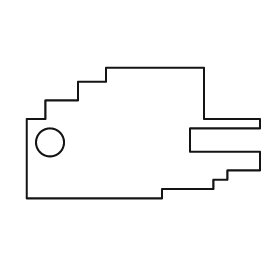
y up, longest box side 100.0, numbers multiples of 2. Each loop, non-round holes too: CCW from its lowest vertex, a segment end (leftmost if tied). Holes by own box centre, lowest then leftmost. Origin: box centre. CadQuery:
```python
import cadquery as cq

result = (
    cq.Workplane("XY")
    .moveTo(-50.0, -28.0)
    .lineTo(8.0, -28.0)
    .lineTo(8.0, -24.0)
    .lineTo(30.0, -24.0)
    .lineTo(30.0, -20.0)
    .lineTo(36.0, -20.0)
    .lineTo(36.0, -16.0)
    .lineTo(50.0, -16.0)
    .lineTo(50.0, -8.0)
    .lineTo(20.0, -8.0)
    .lineTo(20.0, 2.0)
    .lineTo(50.0, 2.0)
    .lineTo(50.0, 6.0)
    .lineTo(26.0, 6.0)
    .lineTo(26.0, 28.0)
    .lineTo(-16.0, 28.0)
    .lineTo(-16.0, 22.0)
    .lineTo(-28.0, 22.0)
    .lineTo(-28.0, 14.0)
    .lineTo(-42.0, 14.0)
    .lineTo(-42.0, 6.0)
    .lineTo(-50.0, 6.0)
    .close()
    .moveTo(-40.0, -4.0)
    .circle(6.0)
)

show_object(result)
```